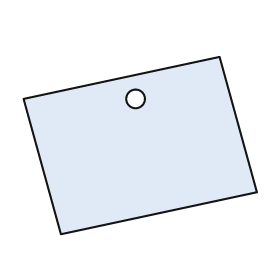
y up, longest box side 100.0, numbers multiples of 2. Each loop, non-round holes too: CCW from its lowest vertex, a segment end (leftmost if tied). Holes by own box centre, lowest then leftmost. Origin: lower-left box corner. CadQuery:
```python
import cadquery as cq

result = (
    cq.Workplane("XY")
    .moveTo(16.0, 0.0)
    .lineTo(100.0, 18.0)
    .lineTo(84.0, 76.0)
    .lineTo(0.0, 58.0)
    .close()
    .moveTo(48.0, 58.0)
    .circle(4.0)
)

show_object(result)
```